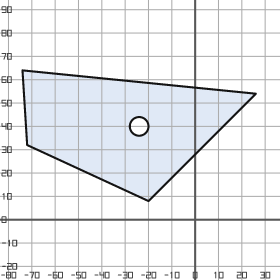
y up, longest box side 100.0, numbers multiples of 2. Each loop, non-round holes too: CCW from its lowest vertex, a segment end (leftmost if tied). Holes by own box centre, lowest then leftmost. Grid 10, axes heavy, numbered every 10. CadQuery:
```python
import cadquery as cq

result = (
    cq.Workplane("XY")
    .moveTo(-20.0, 8.0)
    .lineTo(26.0, 54.0)
    .lineTo(-74.0, 64.0)
    .lineTo(-72.0, 32.0)
    .close()
    .moveTo(-24.0, 40.0)
    .circle(4.0)
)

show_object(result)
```